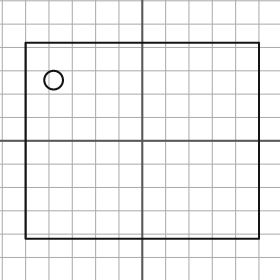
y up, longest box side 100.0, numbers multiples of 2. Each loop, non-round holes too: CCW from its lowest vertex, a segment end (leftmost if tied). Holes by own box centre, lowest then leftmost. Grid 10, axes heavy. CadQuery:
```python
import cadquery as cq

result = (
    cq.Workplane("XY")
    .moveTo(-50.0, -42.0)
    .lineTo(50.0, -42.0)
    .lineTo(50.0, 42.0)
    .lineTo(-50.0, 42.0)
    .close()
    .moveTo(-38.0, 26.0)
    .circle(4.0)
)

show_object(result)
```